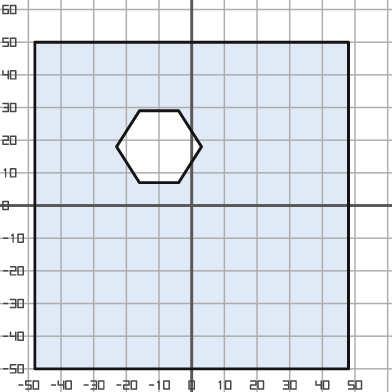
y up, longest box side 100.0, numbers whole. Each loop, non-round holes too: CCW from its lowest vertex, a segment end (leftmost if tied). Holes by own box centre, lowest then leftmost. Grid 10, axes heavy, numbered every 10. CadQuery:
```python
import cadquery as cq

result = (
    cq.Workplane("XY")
    .moveTo(-48.0, -50.0)
    .lineTo(48.0, -50.0)
    .lineTo(48.0, 50.0)
    .lineTo(-48.0, 50.0)
    .close()
    .moveTo(-16.0, 7.0)
    .lineTo(-4.0, 7.0)
    .lineTo(3.0, 18.0)
    .lineTo(-4.0, 29.0)
    .lineTo(-16.0, 29.0)
    .lineTo(-23.0, 18.0)
    .close()
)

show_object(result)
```